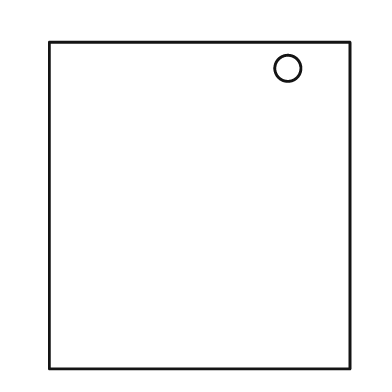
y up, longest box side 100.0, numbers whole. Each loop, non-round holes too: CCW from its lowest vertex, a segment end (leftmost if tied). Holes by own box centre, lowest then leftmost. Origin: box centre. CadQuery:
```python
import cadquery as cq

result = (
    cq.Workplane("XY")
    .moveTo(-46.0, -50.0)
    .lineTo(46.0, -50.0)
    .lineTo(46.0, 50.0)
    .lineTo(-46.0, 50.0)
    .close()
    .moveTo(27.0, 42.0)
    .circle(4.0)
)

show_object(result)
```